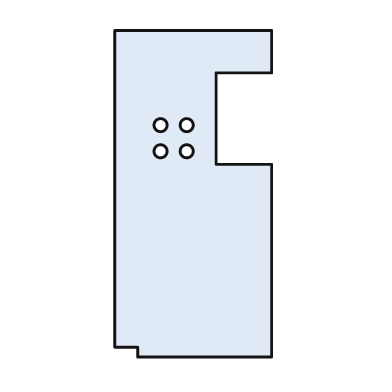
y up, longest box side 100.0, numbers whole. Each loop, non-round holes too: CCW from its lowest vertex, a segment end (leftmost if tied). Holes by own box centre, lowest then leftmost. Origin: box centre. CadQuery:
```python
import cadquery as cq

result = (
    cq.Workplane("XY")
    .moveTo(-17.0, -50.0)
    .lineTo(24.0, -50.0)
    .lineTo(24.0, 9.0)
    .lineTo(7.0, 9.0)
    .lineTo(7.0, 37.0)
    .lineTo(24.0, 37.0)
    .lineTo(24.0, 50.0)
    .lineTo(-24.0, 50.0)
    .lineTo(-24.0, -47.0)
    .lineTo(-17.0, -47.0)
    .close()
    .moveTo(-10.0, 13.0)
    .circle(2.0)
    .moveTo(-2.0, 13.0)
    .circle(2.0)
    .moveTo(-10.0, 21.0)
    .circle(2.0)
    .moveTo(-2.0, 21.0)
    .circle(2.0)
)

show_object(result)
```